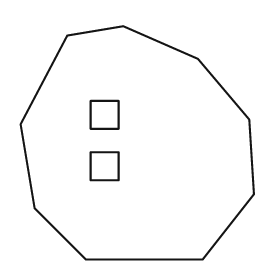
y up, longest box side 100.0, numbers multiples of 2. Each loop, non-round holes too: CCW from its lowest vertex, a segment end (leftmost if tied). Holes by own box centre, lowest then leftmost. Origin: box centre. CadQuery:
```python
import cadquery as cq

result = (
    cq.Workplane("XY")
    .moveTo(-22.0, -50.0)
    .lineTo(28.0, -50.0)
    .lineTo(50.0, -22.0)
    .lineTo(48.0, 10.0)
    .lineTo(26.0, 36.0)
    .lineTo(-6.0, 50.0)
    .lineTo(-30.0, 46.0)
    .lineTo(-50.0, 8.0)
    .lineTo(-44.0, -28.0)
    .close()
    .moveTo(-20.0, -16.0)
    .lineTo(-8.0, -16.0)
    .lineTo(-8.0, -4.0)
    .lineTo(-20.0, -4.0)
    .close()
    .moveTo(-20.0, 6.0)
    .lineTo(-8.0, 6.0)
    .lineTo(-8.0, 18.0)
    .lineTo(-20.0, 18.0)
    .close()
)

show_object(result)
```